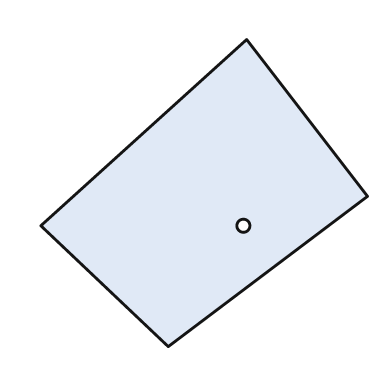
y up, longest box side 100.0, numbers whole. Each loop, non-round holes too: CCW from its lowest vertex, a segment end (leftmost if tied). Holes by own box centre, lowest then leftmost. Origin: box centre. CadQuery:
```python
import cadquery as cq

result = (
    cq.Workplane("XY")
    .moveTo(-11.0, -47.0)
    .lineTo(50.0, -1.0)
    .lineTo(13.0, 47.0)
    .lineTo(-50.0, -10.0)
    .close()
    .moveTo(12.0, -10.0)
    .circle(2.0)
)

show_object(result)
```